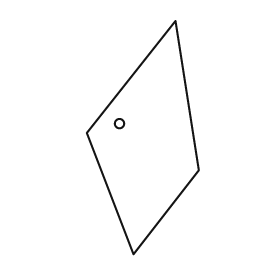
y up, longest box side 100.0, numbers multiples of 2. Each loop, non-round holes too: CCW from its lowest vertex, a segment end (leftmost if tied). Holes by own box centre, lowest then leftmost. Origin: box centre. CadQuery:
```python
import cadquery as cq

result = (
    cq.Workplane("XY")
    .moveTo(-4.0, -50.0)
    .lineTo(24.0, -14.0)
    .lineTo(14.0, 50.0)
    .lineTo(-24.0, 2.0)
    .close()
    .moveTo(-10.0, 6.0)
    .circle(2.0)
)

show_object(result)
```